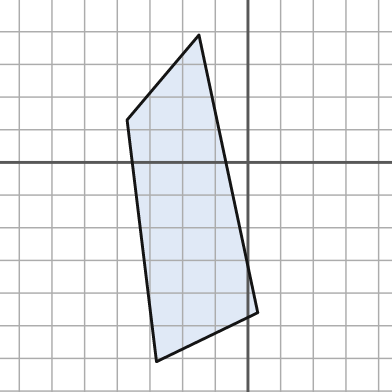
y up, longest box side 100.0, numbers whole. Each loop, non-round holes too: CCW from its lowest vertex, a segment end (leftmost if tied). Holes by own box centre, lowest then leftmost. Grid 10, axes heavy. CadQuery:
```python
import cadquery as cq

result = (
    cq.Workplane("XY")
    .moveTo(-28.0, -61.0)
    .lineTo(3.0, -46.0)
    .lineTo(-15.0, 39.0)
    .lineTo(-37.0, 13.0)
    .close()
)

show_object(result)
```